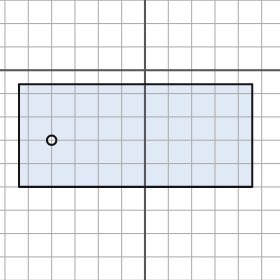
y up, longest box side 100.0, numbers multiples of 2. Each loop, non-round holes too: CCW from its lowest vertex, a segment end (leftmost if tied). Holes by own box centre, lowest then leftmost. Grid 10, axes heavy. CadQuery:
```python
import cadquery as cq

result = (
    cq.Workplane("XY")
    .moveTo(-54.0, -50.0)
    .lineTo(46.0, -50.0)
    .lineTo(46.0, -6.0)
    .lineTo(-54.0, -6.0)
    .close()
    .moveTo(-40.0, -30.0)
    .circle(2.0)
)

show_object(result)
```